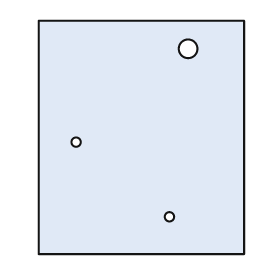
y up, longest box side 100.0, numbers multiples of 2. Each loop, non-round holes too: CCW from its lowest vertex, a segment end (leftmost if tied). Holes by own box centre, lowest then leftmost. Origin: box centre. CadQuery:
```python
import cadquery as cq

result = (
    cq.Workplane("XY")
    .moveTo(-44.0, -50.0)
    .lineTo(44.0, -50.0)
    .lineTo(44.0, 50.0)
    .lineTo(-44.0, 50.0)
    .close()
    .moveTo(12.0, -34.0)
    .circle(2.0)
    .moveTo(-28.0, -2.0)
    .circle(2.0)
    .moveTo(20.0, 38.0)
    .circle(4.0)
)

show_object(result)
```